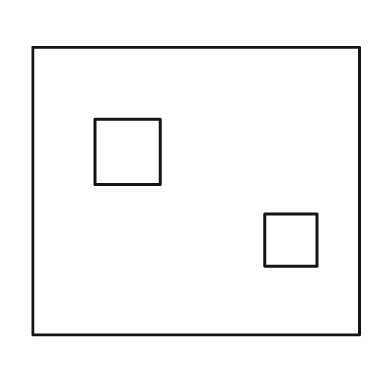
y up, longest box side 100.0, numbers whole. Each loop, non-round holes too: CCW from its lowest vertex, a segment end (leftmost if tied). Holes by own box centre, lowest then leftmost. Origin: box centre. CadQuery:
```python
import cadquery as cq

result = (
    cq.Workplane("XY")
    .moveTo(-50.0, -44.0)
    .lineTo(50.0, -44.0)
    .lineTo(50.0, 44.0)
    .lineTo(-50.0, 44.0)
    .close()
    .moveTo(21.0, -23.0)
    .lineTo(37.0, -23.0)
    .lineTo(37.0, -7.0)
    .lineTo(21.0, -7.0)
    .close()
    .moveTo(-31.0, 2.0)
    .lineTo(-11.0, 2.0)
    .lineTo(-11.0, 22.0)
    .lineTo(-31.0, 22.0)
    .close()
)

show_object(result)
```